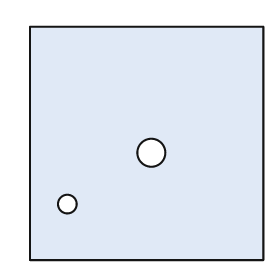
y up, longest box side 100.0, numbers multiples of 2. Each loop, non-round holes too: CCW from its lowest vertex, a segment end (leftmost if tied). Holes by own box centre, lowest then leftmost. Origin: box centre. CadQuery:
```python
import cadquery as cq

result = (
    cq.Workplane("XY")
    .moveTo(-50.0, -50.0)
    .lineTo(50.0, -50.0)
    .lineTo(50.0, 50.0)
    .lineTo(-50.0, 50.0)
    .close()
    .moveTo(-34.0, -26.0)
    .circle(4.0)
    .moveTo(2.0, -4.0)
    .circle(6.0)
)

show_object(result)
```